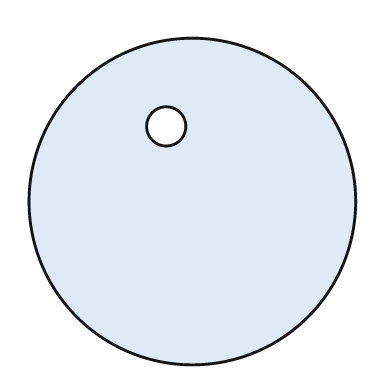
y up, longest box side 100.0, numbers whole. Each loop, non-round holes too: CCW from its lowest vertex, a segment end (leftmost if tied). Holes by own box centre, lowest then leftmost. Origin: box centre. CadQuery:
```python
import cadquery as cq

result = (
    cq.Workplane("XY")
    .moveTo(0.0, 0.0)
    .circle(50.0)
    .moveTo(-8.0, 23.0)
    .circle(6.0)
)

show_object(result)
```